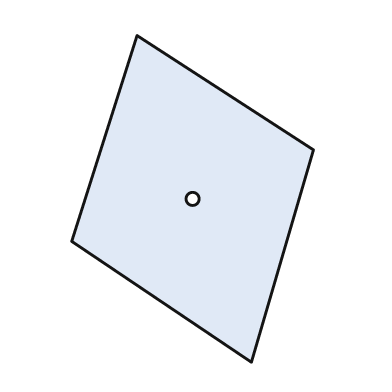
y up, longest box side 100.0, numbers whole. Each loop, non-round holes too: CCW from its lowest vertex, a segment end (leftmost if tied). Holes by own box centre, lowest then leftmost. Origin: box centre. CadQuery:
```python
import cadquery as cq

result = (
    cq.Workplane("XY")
    .moveTo(18.0, -50.0)
    .lineTo(37.0, 15.0)
    .lineTo(-17.0, 50.0)
    .lineTo(-37.0, -13.0)
    .close()
    .moveTo(0.0, 0.0)
    .circle(2.0)
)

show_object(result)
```